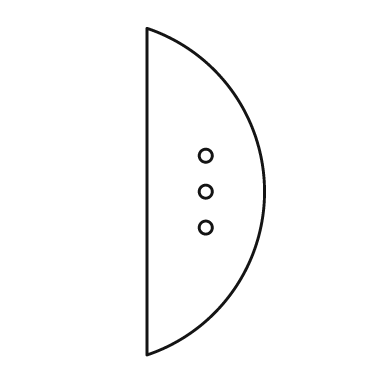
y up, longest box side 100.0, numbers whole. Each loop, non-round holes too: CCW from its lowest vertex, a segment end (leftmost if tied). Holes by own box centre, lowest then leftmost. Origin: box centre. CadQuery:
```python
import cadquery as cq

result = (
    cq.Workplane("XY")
    .moveTo(-18.0, -50.0)
    .threePointArc((18.0, 0.0), (-18.0, 50.0))
    .close()
    .moveTo(0.0, -11.0)
    .circle(2.0)
    .moveTo(0.0, 0.0)
    .circle(2.0)
    .moveTo(0.0, 11.0)
    .circle(2.0)
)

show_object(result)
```